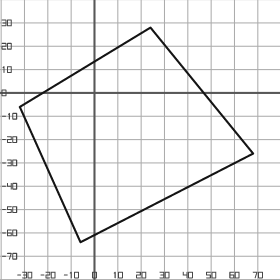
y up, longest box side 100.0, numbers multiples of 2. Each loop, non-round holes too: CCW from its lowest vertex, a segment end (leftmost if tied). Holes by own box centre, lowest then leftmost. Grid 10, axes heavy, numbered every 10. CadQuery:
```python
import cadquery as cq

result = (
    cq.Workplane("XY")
    .moveTo(-6.0, -64.0)
    .lineTo(68.0, -26.0)
    .lineTo(24.0, 28.0)
    .lineTo(-32.0, -6.0)
    .close()
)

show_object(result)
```